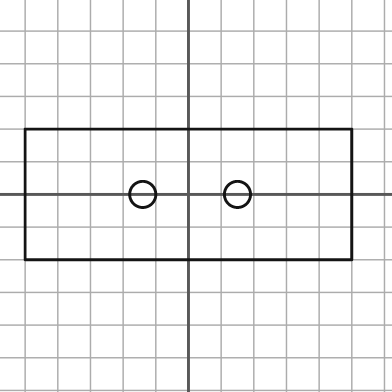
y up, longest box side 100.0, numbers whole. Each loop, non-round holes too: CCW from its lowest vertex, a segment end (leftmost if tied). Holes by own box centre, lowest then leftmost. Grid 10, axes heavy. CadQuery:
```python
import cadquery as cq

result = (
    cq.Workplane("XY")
    .moveTo(-50.0, -20.0)
    .lineTo(50.0, -20.0)
    .lineTo(50.0, 20.0)
    .lineTo(-50.0, 20.0)
    .close()
    .moveTo(-14.0, 0.0)
    .circle(4.0)
    .moveTo(15.0, 0.0)
    .circle(4.0)
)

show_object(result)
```